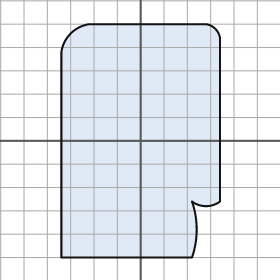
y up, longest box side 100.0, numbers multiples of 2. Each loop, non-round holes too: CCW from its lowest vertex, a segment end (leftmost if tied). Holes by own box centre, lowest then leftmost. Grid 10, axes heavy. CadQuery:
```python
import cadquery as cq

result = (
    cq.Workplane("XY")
    .moveTo(-34.0, -50.0)
    .lineTo(22.0, -50.0)
    .threePointArc((24.0, -38.0), (22.0, -26.0))
    .threePointArc((28.0, -28.0), (34.0, -26.0))
    .lineTo(34.0, 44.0)
    .threePointArc((32.0, 48.0), (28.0, 50.0))
    .lineTo(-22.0, 50.0)
    .threePointArc((-30.0, 46.0), (-34.0, 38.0))
    .close()
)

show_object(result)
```